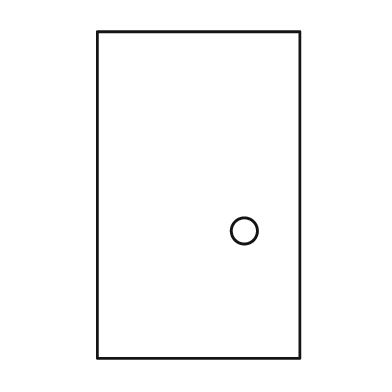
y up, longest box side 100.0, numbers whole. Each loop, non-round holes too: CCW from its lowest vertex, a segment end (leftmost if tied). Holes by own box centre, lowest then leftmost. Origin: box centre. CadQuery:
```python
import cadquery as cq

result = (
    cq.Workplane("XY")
    .moveTo(-31.0, -50.0)
    .lineTo(31.0, -50.0)
    .lineTo(31.0, 50.0)
    .lineTo(-31.0, 50.0)
    .close()
    .moveTo(14.0, -11.0)
    .circle(4.0)
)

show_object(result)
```